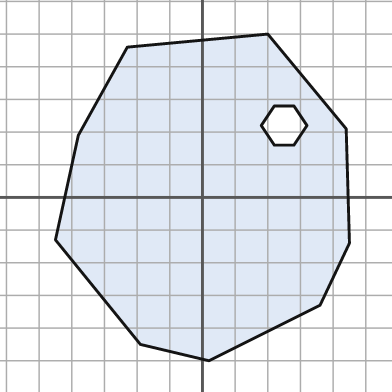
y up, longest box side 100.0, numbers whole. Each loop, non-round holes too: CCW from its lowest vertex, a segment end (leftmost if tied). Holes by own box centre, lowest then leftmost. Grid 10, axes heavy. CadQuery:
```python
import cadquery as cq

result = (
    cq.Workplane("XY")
    .moveTo(2.0, -50.0)
    .lineTo(36.0, -33.0)
    .lineTo(45.0, -14.0)
    .lineTo(44.0, 21.0)
    .lineTo(20.0, 50.0)
    .lineTo(-23.0, 46.0)
    .lineTo(-38.0, 19.0)
    .lineTo(-45.0, -13.0)
    .lineTo(-19.0, -45.0)
    .close()
    .moveTo(22.0, 16.0)
    .lineTo(28.0, 16.0)
    .lineTo(32.0, 22.0)
    .lineTo(28.0, 28.0)
    .lineTo(22.0, 28.0)
    .lineTo(18.0, 22.0)
    .close()
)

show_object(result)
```